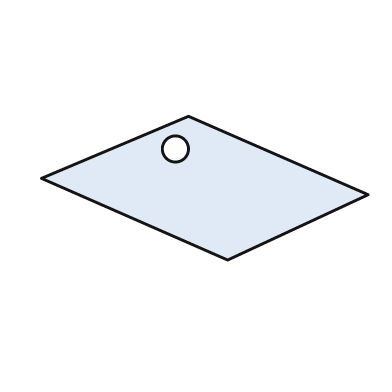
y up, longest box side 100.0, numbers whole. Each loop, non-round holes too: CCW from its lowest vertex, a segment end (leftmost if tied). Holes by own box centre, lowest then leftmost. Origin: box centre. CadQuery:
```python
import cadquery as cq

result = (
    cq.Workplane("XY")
    .moveTo(7.0, -22.0)
    .lineTo(50.0, -2.0)
    .lineTo(-5.0, 22.0)
    .lineTo(-50.0, 3.0)
    .close()
    .moveTo(-9.0, 12.0)
    .circle(4.0)
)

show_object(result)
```